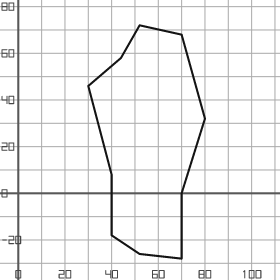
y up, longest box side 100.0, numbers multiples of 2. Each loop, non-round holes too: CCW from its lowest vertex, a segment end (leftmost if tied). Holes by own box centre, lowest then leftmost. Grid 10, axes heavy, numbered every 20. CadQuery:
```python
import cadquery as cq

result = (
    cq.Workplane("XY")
    .moveTo(70.0, -28.0)
    .lineTo(70.0, 0.0)
    .lineTo(80.0, 32.0)
    .lineTo(70.0, 68.0)
    .lineTo(52.0, 72.0)
    .lineTo(44.0, 58.0)
    .lineTo(30.0, 46.0)
    .lineTo(40.0, 8.0)
    .lineTo(40.0, -18.0)
    .lineTo(52.0, -26.0)
    .close()
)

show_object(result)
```